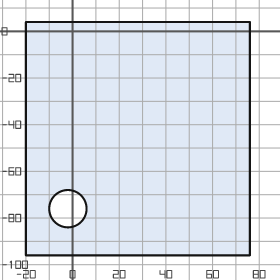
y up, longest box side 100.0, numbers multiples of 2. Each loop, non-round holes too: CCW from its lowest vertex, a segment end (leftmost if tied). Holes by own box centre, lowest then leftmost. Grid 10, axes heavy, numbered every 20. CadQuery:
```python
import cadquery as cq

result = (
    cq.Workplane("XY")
    .moveTo(-20.0, -96.0)
    .lineTo(76.0, -96.0)
    .lineTo(76.0, 4.0)
    .lineTo(-20.0, 4.0)
    .close()
    .moveTo(-2.0, -76.0)
    .circle(8.0)
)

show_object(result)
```